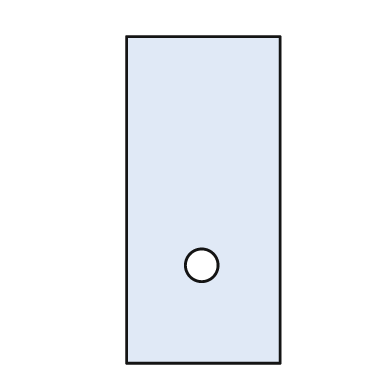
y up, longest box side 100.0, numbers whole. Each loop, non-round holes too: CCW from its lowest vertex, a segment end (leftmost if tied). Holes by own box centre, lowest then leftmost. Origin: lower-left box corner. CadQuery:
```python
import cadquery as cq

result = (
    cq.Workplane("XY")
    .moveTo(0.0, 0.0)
    .lineTo(47.0, 0.0)
    .lineTo(47.0, 100.0)
    .lineTo(0.0, 100.0)
    .close()
    .moveTo(23.0, 30.0)
    .circle(5.0)
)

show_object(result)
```